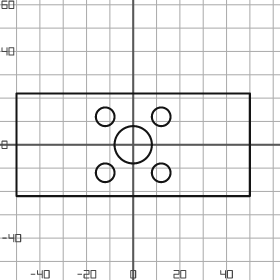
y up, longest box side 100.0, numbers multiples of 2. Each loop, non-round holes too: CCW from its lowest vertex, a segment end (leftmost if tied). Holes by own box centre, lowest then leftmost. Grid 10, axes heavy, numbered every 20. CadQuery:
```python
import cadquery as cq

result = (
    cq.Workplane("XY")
    .moveTo(-50.0, -22.0)
    .lineTo(50.0, -22.0)
    .lineTo(50.0, 22.0)
    .lineTo(-50.0, 22.0)
    .close()
    .moveTo(-12.0, -12.0)
    .circle(4.0)
    .moveTo(12.0, -12.0)
    .circle(4.0)
    .moveTo(0.0, 0.0)
    .circle(8.0)
    .moveTo(-12.0, 12.0)
    .circle(4.0)
    .moveTo(12.0, 12.0)
    .circle(4.0)
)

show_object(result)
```